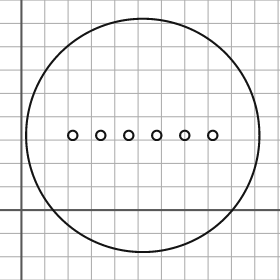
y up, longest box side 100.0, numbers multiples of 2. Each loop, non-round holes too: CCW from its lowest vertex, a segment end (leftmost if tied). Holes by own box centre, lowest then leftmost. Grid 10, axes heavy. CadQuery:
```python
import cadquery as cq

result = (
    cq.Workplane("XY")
    .moveTo(52.0, 32.0)
    .circle(50.0)
    .moveTo(22.0, 32.0)
    .circle(2.0)
    .moveTo(34.0, 32.0)
    .circle(2.0)
    .moveTo(46.0, 32.0)
    .circle(2.0)
    .moveTo(58.0, 32.0)
    .circle(2.0)
    .moveTo(70.0, 32.0)
    .circle(2.0)
    .moveTo(82.0, 32.0)
    .circle(2.0)
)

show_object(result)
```